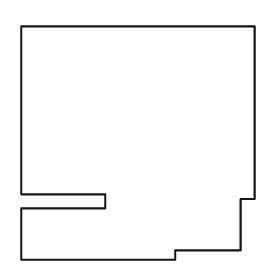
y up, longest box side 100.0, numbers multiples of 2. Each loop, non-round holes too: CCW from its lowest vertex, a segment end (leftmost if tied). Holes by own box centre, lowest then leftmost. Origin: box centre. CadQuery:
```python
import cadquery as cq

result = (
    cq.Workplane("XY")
    .moveTo(-50.0, -50.0)
    .lineTo(16.0, -50.0)
    .lineTo(16.0, -46.0)
    .lineTo(44.0, -46.0)
    .lineTo(44.0, -24.0)
    .lineTo(50.0, -24.0)
    .lineTo(50.0, 50.0)
    .lineTo(-50.0, 50.0)
    .lineTo(-50.0, -22.0)
    .lineTo(-14.0, -22.0)
    .lineTo(-14.0, -28.0)
    .lineTo(-50.0, -28.0)
    .close()
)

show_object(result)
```